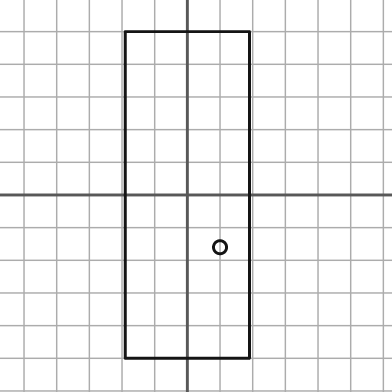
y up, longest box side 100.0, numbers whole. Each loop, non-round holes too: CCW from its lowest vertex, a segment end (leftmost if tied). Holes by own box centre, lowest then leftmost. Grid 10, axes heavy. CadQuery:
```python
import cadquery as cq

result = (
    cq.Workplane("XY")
    .moveTo(-19.0, -50.0)
    .lineTo(19.0, -50.0)
    .lineTo(19.0, 50.0)
    .lineTo(-19.0, 50.0)
    .close()
    .moveTo(10.0, -16.0)
    .circle(2.0)
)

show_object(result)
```